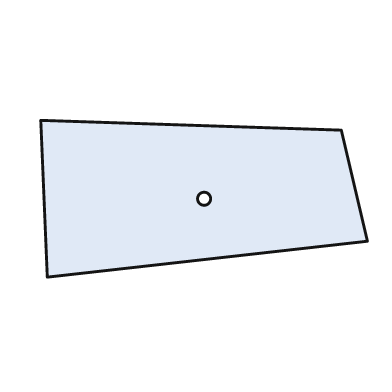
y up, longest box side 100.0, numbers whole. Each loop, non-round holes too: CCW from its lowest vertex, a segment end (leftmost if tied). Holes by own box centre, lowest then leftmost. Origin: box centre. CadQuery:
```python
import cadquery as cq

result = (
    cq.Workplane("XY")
    .moveTo(-48.0, -24.0)
    .lineTo(50.0, -13.0)
    .lineTo(42.0, 21.0)
    .lineTo(-50.0, 24.0)
    .close()
    .moveTo(0.0, 0.0)
    .circle(2.0)
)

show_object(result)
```